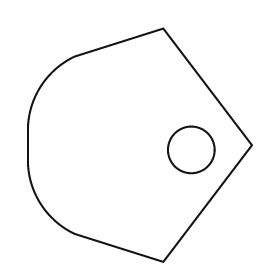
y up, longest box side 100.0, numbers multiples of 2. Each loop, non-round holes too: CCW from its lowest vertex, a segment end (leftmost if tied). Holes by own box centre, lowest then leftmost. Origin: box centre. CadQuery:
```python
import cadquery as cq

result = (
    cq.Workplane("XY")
    .moveTo(10.0, -50.0)
    .lineTo(48.0, 0.0)
    .lineTo(10.0, 50.0)
    .lineTo(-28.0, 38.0)
    .threePointArc((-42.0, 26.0), (-48.0, 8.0))
    .lineTo(-48.0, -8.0)
    .threePointArc((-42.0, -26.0), (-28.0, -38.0))
    .close()
    .moveTo(22.0, -2.0)
    .circle(10.0)
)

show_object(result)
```